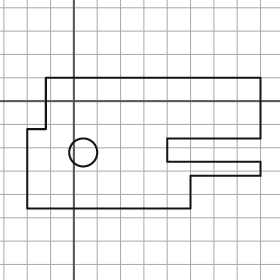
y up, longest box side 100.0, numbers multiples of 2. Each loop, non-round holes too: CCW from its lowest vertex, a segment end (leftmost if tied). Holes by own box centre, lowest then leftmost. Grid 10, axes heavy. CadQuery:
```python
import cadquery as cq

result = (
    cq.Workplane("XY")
    .moveTo(-20.0, -46.0)
    .lineTo(50.0, -46.0)
    .lineTo(50.0, -32.0)
    .lineTo(80.0, -32.0)
    .lineTo(80.0, -26.0)
    .lineTo(40.0, -26.0)
    .lineTo(40.0, -16.0)
    .lineTo(80.0, -16.0)
    .lineTo(80.0, 10.0)
    .lineTo(-12.0, 10.0)
    .lineTo(-12.0, -12.0)
    .lineTo(-20.0, -12.0)
    .close()
    .moveTo(4.0, -22.0)
    .circle(6.0)
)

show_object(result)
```